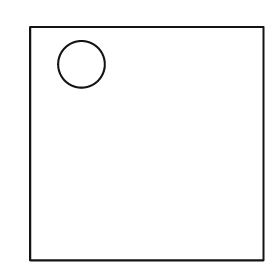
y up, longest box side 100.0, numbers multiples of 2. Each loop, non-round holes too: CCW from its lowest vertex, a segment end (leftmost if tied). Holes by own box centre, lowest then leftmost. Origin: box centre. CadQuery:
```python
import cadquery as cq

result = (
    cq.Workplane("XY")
    .moveTo(-50.0, -50.0)
    .lineTo(50.0, -50.0)
    .lineTo(50.0, 50.0)
    .lineTo(-50.0, 50.0)
    .close()
    .moveTo(-28.0, 34.0)
    .circle(10.0)
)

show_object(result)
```